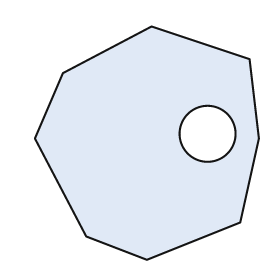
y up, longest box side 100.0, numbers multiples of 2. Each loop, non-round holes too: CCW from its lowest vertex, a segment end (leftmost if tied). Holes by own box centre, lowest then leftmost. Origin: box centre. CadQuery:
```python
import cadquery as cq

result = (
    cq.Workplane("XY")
    .moveTo(0.0, -50.0)
    .lineTo(40.0, -34.0)
    .lineTo(48.0, 2.0)
    .lineTo(44.0, 36.0)
    .lineTo(2.0, 50.0)
    .lineTo(-36.0, 30.0)
    .lineTo(-48.0, 2.0)
    .lineTo(-26.0, -40.0)
    .close()
    .moveTo(26.0, 4.0)
    .circle(12.0)
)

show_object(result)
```